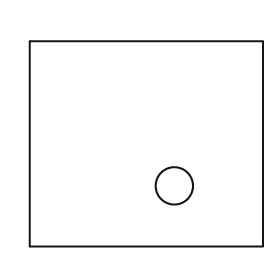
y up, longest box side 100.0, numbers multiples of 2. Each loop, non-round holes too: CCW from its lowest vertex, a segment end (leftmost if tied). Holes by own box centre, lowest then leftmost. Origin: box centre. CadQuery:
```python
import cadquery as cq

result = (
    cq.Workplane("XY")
    .moveTo(-50.0, -44.0)
    .lineTo(50.0, -44.0)
    .lineTo(50.0, 44.0)
    .lineTo(-50.0, 44.0)
    .close()
    .moveTo(12.0, -18.0)
    .circle(8.0)
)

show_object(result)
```